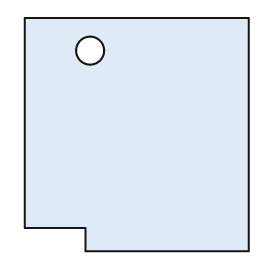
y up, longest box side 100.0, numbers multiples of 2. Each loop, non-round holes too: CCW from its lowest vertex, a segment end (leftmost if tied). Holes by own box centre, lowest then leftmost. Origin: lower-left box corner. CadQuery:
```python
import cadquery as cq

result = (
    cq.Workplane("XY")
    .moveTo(26.0, 0.0)
    .lineTo(96.0, 0.0)
    .lineTo(96.0, 100.0)
    .lineTo(0.0, 100.0)
    .lineTo(0.0, 10.0)
    .lineTo(26.0, 10.0)
    .close()
    .moveTo(28.0, 86.0)
    .circle(6.0)
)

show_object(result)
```